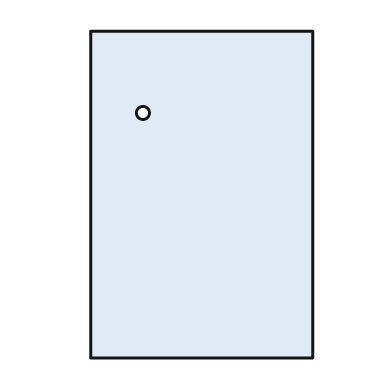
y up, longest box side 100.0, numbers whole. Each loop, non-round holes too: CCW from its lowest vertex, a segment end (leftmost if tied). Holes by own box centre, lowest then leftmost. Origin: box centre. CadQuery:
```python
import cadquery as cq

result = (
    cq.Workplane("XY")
    .moveTo(-34.0, -50.0)
    .lineTo(34.0, -50.0)
    .lineTo(34.0, 50.0)
    .lineTo(-34.0, 50.0)
    .close()
    .moveTo(-18.0, 25.0)
    .circle(2.0)
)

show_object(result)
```